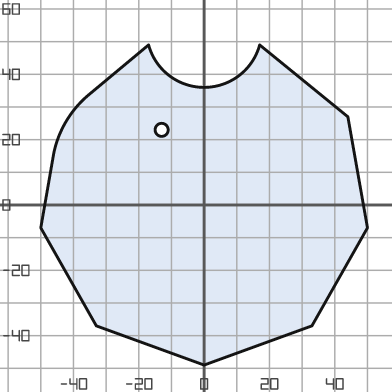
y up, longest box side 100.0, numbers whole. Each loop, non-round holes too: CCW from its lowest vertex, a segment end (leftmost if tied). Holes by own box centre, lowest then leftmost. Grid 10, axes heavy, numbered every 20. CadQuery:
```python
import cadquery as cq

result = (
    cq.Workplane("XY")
    .moveTo(0.0, -49.0)
    .lineTo(33.0, -37.0)
    .lineTo(50.0, -7.0)
    .lineTo(44.0, 27.0)
    .lineTo(17.0, 49.0)
    .threePointArc((0.0, 36.0), (-17.0, 49.0))
    .lineTo(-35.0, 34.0)
    .threePointArc((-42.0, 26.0), (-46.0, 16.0))
    .lineTo(-50.0, -7.0)
    .lineTo(-33.0, -37.0)
    .close()
    .moveTo(-13.0, 23.0)
    .circle(2.0)
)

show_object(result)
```